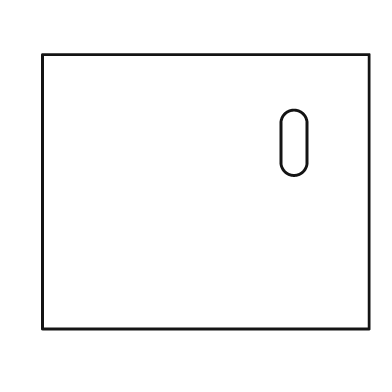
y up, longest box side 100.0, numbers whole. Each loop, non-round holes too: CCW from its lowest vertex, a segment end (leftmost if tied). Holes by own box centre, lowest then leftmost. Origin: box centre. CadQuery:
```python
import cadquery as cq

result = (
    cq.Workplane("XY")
    .moveTo(-50.0, -42.0)
    .lineTo(50.0, -42.0)
    .lineTo(50.0, 42.0)
    .lineTo(-50.0, 42.0)
    .close()
    .moveTo(23.0, 9.0)
    .threePointArc((27.0, 5.0), (31.0, 9.0))
    .lineTo(31.0, 21.0)
    .threePointArc((27.0, 25.0), (23.0, 21.0))
    .close()
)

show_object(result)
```